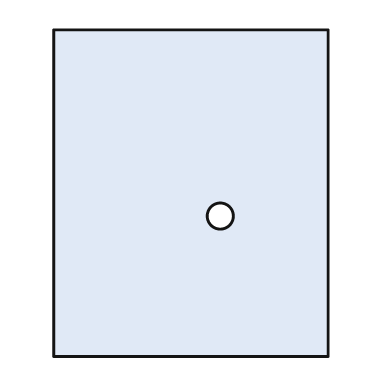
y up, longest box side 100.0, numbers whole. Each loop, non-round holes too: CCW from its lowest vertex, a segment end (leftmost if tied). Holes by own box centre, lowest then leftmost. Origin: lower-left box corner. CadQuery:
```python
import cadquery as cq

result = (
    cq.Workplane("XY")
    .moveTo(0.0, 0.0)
    .lineTo(84.0, 0.0)
    .lineTo(84.0, 100.0)
    .lineTo(0.0, 100.0)
    .close()
    .moveTo(51.0, 43.0)
    .circle(4.0)
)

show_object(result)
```